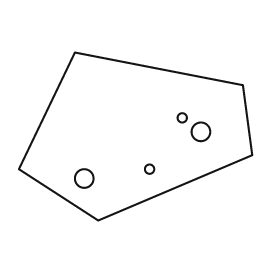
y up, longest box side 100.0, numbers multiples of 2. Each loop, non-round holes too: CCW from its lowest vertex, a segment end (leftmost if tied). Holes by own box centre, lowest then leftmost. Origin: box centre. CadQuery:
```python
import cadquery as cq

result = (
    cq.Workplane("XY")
    .moveTo(-16.0, -36.0)
    .lineTo(50.0, -8.0)
    .lineTo(46.0, 22.0)
    .lineTo(-26.0, 36.0)
    .lineTo(-50.0, -14.0)
    .close()
    .moveTo(-22.0, -18.0)
    .circle(4.0)
    .moveTo(6.0, -14.0)
    .circle(2.0)
    .moveTo(28.0, 2.0)
    .circle(4.0)
    .moveTo(20.0, 8.0)
    .circle(2.0)
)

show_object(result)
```